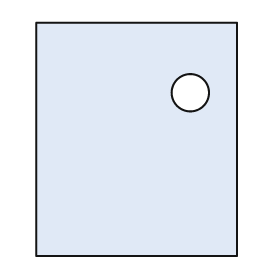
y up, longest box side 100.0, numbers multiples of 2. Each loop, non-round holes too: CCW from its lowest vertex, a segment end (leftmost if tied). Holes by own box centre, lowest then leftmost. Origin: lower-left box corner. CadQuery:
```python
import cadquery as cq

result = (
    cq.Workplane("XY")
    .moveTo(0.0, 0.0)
    .lineTo(86.0, 0.0)
    .lineTo(86.0, 100.0)
    .lineTo(0.0, 100.0)
    .close()
    .moveTo(66.0, 70.0)
    .circle(8.0)
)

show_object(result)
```